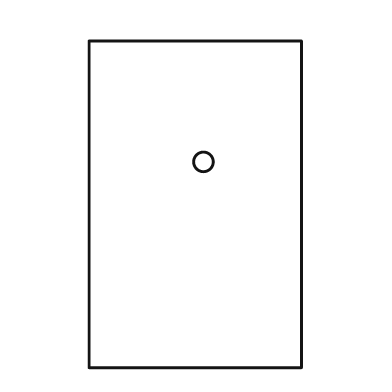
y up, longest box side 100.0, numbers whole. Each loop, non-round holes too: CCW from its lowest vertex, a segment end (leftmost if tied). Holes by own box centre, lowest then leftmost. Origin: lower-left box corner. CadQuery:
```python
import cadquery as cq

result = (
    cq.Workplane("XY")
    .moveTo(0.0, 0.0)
    .lineTo(65.0, 0.0)
    .lineTo(65.0, 100.0)
    .lineTo(0.0, 100.0)
    .close()
    .moveTo(35.0, 63.0)
    .circle(3.0)
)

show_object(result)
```